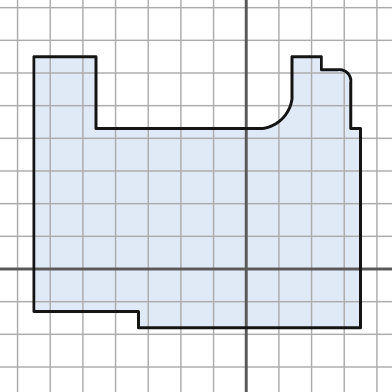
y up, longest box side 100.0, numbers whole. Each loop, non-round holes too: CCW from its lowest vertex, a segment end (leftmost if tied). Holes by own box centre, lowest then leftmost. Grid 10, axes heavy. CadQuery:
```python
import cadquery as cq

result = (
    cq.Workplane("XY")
    .moveTo(-33.0, -18.0)
    .lineTo(35.0, -18.0)
    .lineTo(35.0, 43.0)
    .lineTo(32.0, 43.0)
    .lineTo(32.0, 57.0)
    .threePointArc((31.0, 60.0), (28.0, 61.0))
    .lineTo(23.0, 61.0)
    .lineTo(23.0, 65.0)
    .lineTo(14.0, 65.0)
    .lineTo(14.0, 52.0)
    .threePointArc((11.0, 46.0), (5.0, 43.0))
    .lineTo(-46.0, 43.0)
    .lineTo(-46.0, 65.0)
    .lineTo(-65.0, 65.0)
    .lineTo(-65.0, -13.0)
    .lineTo(-33.0, -13.0)
    .close()
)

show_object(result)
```